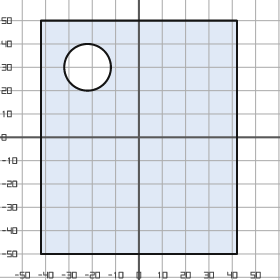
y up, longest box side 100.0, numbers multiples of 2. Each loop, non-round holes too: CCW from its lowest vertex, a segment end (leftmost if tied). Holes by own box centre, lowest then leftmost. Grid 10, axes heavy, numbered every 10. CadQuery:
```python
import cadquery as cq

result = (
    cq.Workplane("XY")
    .moveTo(-42.0, -50.0)
    .lineTo(42.0, -50.0)
    .lineTo(42.0, 50.0)
    .lineTo(-42.0, 50.0)
    .close()
    .moveTo(-22.0, 30.0)
    .circle(10.0)
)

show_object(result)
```